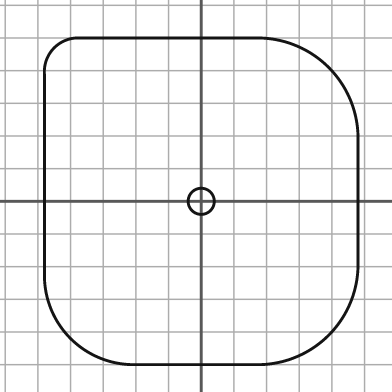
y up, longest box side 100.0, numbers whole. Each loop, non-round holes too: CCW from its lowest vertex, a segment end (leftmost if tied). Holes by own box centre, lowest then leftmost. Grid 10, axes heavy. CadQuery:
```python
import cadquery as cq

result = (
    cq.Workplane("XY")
    .moveTo(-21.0, -50.0)
    .lineTo(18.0, -50.0)
    .threePointArc((39.0, -41.0), (48.0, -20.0))
    .lineTo(48.0, 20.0)
    .threePointArc((39.0, 41.0), (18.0, 50.0))
    .lineTo(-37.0, 50.0)
    .threePointArc((-45.0, 47.0), (-48.0, 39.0))
    .lineTo(-48.0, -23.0)
    .threePointArc((-40.0, -42.0), (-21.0, -50.0))
    .close()
    .moveTo(0.0, 0.0)
    .circle(4.0)
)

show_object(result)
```